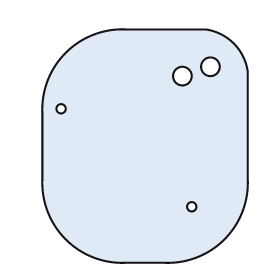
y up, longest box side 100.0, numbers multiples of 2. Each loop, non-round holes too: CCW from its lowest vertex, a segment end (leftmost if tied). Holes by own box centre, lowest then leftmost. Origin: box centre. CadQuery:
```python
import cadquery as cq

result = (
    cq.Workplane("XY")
    .moveTo(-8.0, -50.0)
    .lineTo(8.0, -50.0)
    .threePointArc((34.0, -40.0), (44.0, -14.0))
    .lineTo(44.0, 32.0)
    .threePointArc((38.0, 44.0), (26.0, 50.0))
    .lineTo(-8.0, 50.0)
    .threePointArc((-34.0, 40.0), (-44.0, 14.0))
    .lineTo(-44.0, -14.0)
    .threePointArc((-34.0, -40.0), (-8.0, -50.0))
    .close()
    .moveTo(20.0, -26.0)
    .circle(2.0)
    .moveTo(-36.0, 16.0)
    .circle(2.0)
    .moveTo(16.0, 30.0)
    .circle(4.0)
    .moveTo(28.0, 34.0)
    .circle(4.0)
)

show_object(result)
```